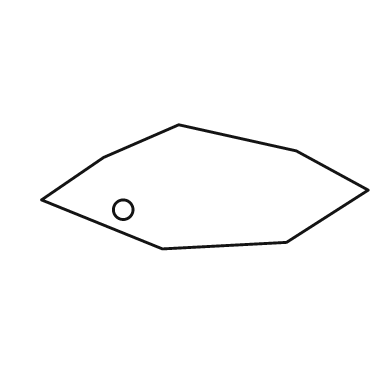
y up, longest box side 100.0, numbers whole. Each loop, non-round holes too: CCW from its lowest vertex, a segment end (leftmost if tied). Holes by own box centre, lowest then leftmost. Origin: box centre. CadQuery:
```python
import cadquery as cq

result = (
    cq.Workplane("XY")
    .moveTo(-13.0, -19.0)
    .lineTo(25.0, -17.0)
    .lineTo(50.0, -1.0)
    .lineTo(28.0, 11.0)
    .lineTo(-8.0, 19.0)
    .lineTo(-31.0, 9.0)
    .lineTo(-50.0, -4.0)
    .close()
    .moveTo(-25.0, -7.0)
    .circle(3.0)
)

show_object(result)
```